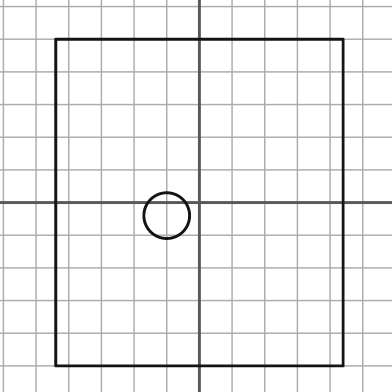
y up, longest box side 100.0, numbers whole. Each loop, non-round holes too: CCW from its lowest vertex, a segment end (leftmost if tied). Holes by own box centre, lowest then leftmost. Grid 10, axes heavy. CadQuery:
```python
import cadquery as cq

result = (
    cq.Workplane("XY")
    .moveTo(-44.0, -50.0)
    .lineTo(44.0, -50.0)
    .lineTo(44.0, 50.0)
    .lineTo(-44.0, 50.0)
    .close()
    .moveTo(-10.0, -4.0)
    .circle(7.0)
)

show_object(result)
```